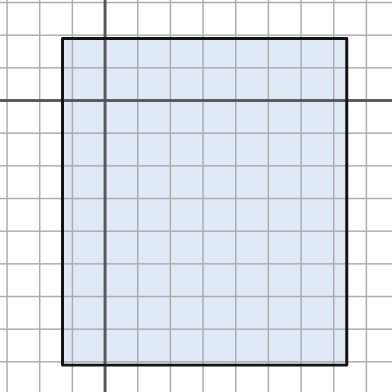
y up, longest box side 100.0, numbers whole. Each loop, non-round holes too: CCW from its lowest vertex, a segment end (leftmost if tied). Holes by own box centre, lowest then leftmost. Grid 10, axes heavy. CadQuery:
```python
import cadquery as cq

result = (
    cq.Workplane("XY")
    .moveTo(-13.0, -81.0)
    .lineTo(74.0, -81.0)
    .lineTo(74.0, 19.0)
    .lineTo(-13.0, 19.0)
    .close()
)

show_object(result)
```